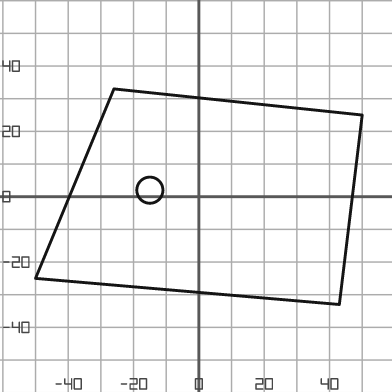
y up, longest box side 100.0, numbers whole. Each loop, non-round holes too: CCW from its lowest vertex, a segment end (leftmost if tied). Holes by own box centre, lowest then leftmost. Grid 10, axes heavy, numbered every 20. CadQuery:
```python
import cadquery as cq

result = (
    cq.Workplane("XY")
    .moveTo(43.0, -33.0)
    .lineTo(50.0, 25.0)
    .lineTo(-26.0, 33.0)
    .lineTo(-50.0, -25.0)
    .close()
    .moveTo(-15.0, 2.0)
    .circle(4.0)
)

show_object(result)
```